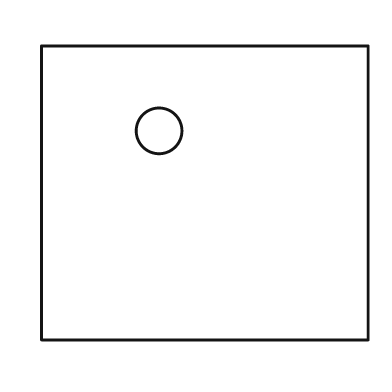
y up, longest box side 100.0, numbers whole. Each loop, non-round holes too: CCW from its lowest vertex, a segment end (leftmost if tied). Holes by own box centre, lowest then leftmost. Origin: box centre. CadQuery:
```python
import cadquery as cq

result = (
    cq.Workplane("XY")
    .moveTo(-50.0, -45.0)
    .lineTo(50.0, -45.0)
    .lineTo(50.0, 45.0)
    .lineTo(-50.0, 45.0)
    .close()
    .moveTo(-14.0, 19.0)
    .circle(7.0)
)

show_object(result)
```